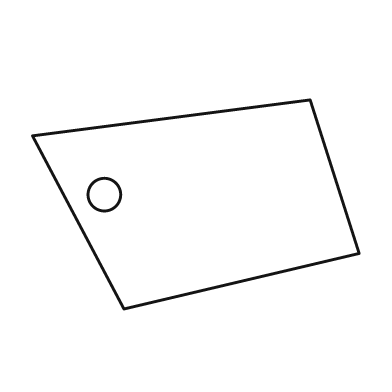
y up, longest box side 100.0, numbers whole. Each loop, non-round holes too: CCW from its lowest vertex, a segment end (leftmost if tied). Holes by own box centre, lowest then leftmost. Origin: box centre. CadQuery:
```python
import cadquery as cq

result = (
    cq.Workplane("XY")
    .moveTo(-22.0, -32.0)
    .lineTo(50.0, -15.0)
    .lineTo(35.0, 32.0)
    .lineTo(-50.0, 21.0)
    .close()
    .moveTo(-28.0, 3.0)
    .circle(5.0)
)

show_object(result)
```